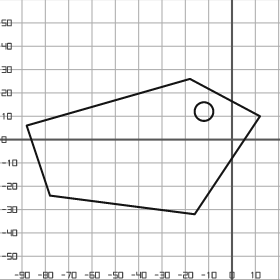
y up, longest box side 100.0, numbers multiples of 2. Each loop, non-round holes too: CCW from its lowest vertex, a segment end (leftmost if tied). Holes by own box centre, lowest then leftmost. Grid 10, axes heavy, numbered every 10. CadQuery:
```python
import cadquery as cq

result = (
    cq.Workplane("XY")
    .moveTo(-16.0, -32.0)
    .lineTo(12.0, 10.0)
    .lineTo(-18.0, 26.0)
    .lineTo(-88.0, 6.0)
    .lineTo(-78.0, -24.0)
    .close()
    .moveTo(-12.0, 12.0)
    .circle(4.0)
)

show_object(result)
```